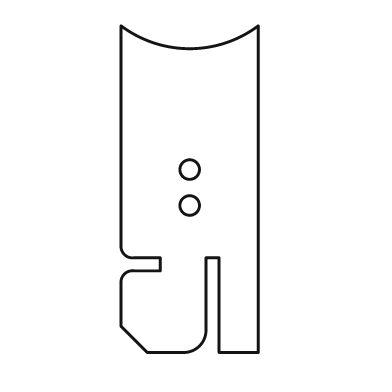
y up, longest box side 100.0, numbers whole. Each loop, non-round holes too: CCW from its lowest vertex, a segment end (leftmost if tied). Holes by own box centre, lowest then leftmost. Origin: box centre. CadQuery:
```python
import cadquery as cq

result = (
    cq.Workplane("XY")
    .moveTo(-13.0, -50.0)
    .lineTo(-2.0, -50.0)
    .threePointArc((3.0, -48.0), (5.0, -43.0))
    .lineTo(5.0, -21.0)
    .lineTo(9.0, -21.0)
    .lineTo(9.0, -50.0)
    .lineTo(21.0, -50.0)
    .lineTo(21.0, 50.0)
    .threePointArc((0.0, 43.0), (-21.0, 50.0))
    .lineTo(-21.0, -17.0)
    .threePointArc((-20.0, -20.0), (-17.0, -21.0))
    .lineTo(-9.0, -21.0)
    .lineTo(-9.0, -25.0)
    .lineTo(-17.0, -25.0)
    .threePointArc((-20.0, -26.0), (-21.0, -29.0))
    .lineTo(-21.0, -42.0)
    .close()
    .moveTo(0.0, -5.0)
    .circle(3.0)
    .moveTo(0.0, 6.0)
    .circle(3.0)
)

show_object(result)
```